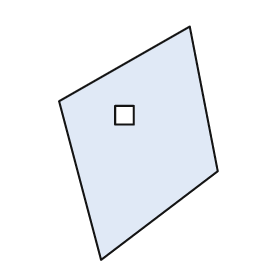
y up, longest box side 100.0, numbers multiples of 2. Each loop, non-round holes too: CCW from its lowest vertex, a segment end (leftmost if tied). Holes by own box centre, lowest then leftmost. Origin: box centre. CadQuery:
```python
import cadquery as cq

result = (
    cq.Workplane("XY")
    .moveTo(-16.0, -50.0)
    .lineTo(34.0, -12.0)
    .lineTo(22.0, 50.0)
    .lineTo(-34.0, 18.0)
    .close()
    .moveTo(-10.0, 8.0)
    .lineTo(-2.0, 8.0)
    .lineTo(-2.0, 16.0)
    .lineTo(-10.0, 16.0)
    .close()
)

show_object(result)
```